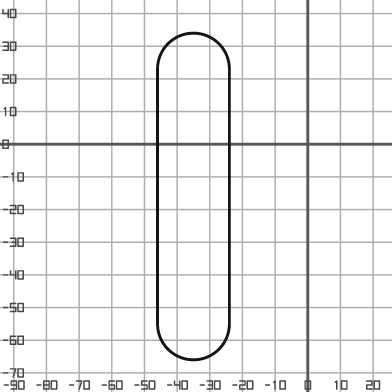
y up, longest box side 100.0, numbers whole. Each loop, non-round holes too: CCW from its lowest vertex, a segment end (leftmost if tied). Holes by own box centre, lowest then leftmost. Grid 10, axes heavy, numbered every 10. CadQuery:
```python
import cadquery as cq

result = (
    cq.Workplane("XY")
    .moveTo(-46.0, -55.0)
    .threePointArc((-35.0, -66.0), (-24.0, -55.0))
    .lineTo(-24.0, 23.0)
    .threePointArc((-35.0, 34.0), (-46.0, 23.0))
    .close()
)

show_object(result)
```